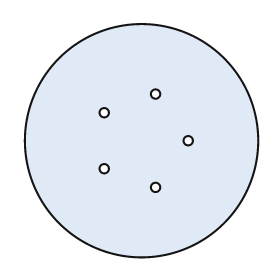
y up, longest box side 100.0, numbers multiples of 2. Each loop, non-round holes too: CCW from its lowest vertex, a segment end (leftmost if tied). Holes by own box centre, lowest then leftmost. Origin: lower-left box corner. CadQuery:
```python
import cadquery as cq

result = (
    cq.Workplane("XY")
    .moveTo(50.0, 50.0)
    .circle(50.0)
    .moveTo(56.0, 30.0)
    .circle(2.0)
    .moveTo(34.0, 38.0)
    .circle(2.0)
    .moveTo(70.0, 50.0)
    .circle(2.0)
    .moveTo(34.0, 62.0)
    .circle(2.0)
    .moveTo(56.0, 70.0)
    .circle(2.0)
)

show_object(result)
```